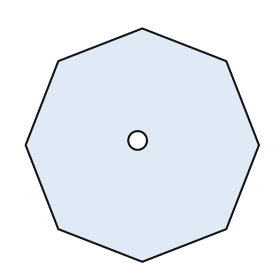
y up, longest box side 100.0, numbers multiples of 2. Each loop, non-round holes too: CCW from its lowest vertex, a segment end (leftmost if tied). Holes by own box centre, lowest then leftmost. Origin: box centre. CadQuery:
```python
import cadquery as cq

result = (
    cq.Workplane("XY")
    .moveTo(0.0, -50.0)
    .lineTo(36.0, -36.0)
    .lineTo(50.0, 0.0)
    .lineTo(36.0, 36.0)
    .lineTo(0.0, 50.0)
    .lineTo(-36.0, 36.0)
    .lineTo(-50.0, 0.0)
    .lineTo(-36.0, -36.0)
    .close()
    .moveTo(-2.0, 2.0)
    .circle(4.0)
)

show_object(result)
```